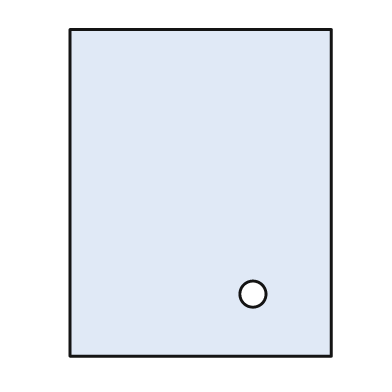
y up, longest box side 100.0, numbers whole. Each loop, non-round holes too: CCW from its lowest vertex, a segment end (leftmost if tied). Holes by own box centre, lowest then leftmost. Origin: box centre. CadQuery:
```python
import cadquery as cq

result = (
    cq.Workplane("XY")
    .moveTo(-40.0, -50.0)
    .lineTo(40.0, -50.0)
    .lineTo(40.0, 50.0)
    .lineTo(-40.0, 50.0)
    .close()
    .moveTo(16.0, -31.0)
    .circle(4.0)
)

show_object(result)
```